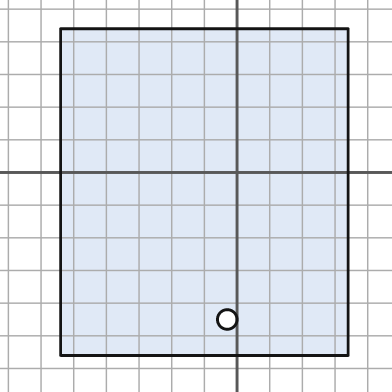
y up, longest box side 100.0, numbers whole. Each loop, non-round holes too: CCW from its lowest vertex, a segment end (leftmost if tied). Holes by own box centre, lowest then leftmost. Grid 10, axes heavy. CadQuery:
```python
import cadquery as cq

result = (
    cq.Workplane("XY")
    .moveTo(-54.0, -56.0)
    .lineTo(34.0, -56.0)
    .lineTo(34.0, 44.0)
    .lineTo(-54.0, 44.0)
    .close()
    .moveTo(-3.0, -45.0)
    .circle(3.0)
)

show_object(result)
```